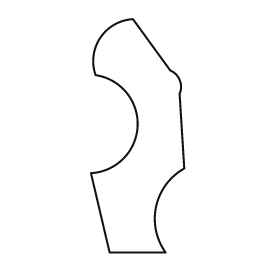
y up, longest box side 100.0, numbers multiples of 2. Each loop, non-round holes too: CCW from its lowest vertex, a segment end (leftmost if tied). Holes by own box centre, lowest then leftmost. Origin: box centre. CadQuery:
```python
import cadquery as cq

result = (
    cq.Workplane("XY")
    .moveTo(-12.0, -50.0)
    .lineTo(12.0, -50.0)
    .threePointArc((8.0, -30.0), (20.0, -14.0))
    .lineTo(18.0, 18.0)
    .threePointArc((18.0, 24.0), (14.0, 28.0))
    .lineTo(-2.0, 50.0)
    .threePointArc((-16.0, 42.0), (-18.0, 26.0))
    .threePointArc((0.0, 4.0), (-20.0, -16.0))
    .close()
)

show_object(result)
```